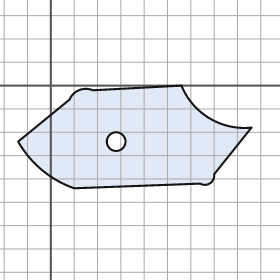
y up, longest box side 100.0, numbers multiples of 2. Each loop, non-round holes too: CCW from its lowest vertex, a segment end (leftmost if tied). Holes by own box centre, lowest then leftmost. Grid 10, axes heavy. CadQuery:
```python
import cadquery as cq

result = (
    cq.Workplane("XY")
    .moveTo(10.0, -44.0)
    .lineTo(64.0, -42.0)
    .threePointArc((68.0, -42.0), (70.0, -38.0))
    .lineTo(86.0, -18.0)
    .threePointArc((68.0, -14.0), (56.0, 0.0))
    .lineTo(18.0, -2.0)
    .threePointArc((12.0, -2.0), (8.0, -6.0))
    .lineTo(-14.0, -24.0)
    .threePointArc((-4.0, -36.0), (10.0, -44.0))
    .close()
    .moveTo(28.0, -24.0)
    .circle(4.0)
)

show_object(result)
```